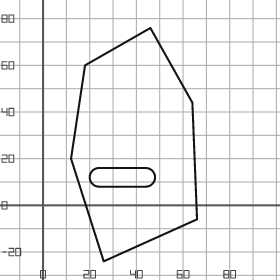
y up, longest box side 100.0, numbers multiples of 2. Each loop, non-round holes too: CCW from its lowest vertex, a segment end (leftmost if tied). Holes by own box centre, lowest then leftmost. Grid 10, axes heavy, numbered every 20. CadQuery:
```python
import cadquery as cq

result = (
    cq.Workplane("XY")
    .moveTo(26.0, -24.0)
    .lineTo(66.0, -6.0)
    .lineTo(64.0, 44.0)
    .lineTo(46.0, 76.0)
    .lineTo(18.0, 60.0)
    .lineTo(12.0, 20.0)
    .close()
    .moveTo(24.0, 8.0)
    .lineTo(44.0, 8.0)
    .threePointArc((48.0, 12.0), (44.0, 16.0))
    .lineTo(24.0, 16.0)
    .threePointArc((20.0, 12.0), (24.0, 8.0))
    .close()
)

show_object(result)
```